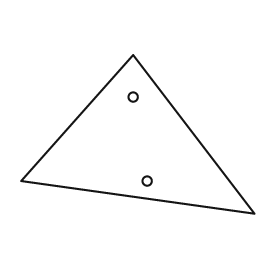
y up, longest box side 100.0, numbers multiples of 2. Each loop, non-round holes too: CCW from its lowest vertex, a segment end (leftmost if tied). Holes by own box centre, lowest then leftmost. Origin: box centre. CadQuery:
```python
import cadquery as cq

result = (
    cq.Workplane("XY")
    .moveTo(50.0, -34.0)
    .lineTo(-2.0, 34.0)
    .lineTo(-50.0, -20.0)
    .close()
    .moveTo(4.0, -20.0)
    .circle(2.0)
    .moveTo(-2.0, 16.0)
    .circle(2.0)
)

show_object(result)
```